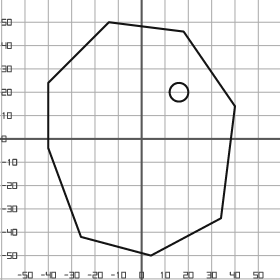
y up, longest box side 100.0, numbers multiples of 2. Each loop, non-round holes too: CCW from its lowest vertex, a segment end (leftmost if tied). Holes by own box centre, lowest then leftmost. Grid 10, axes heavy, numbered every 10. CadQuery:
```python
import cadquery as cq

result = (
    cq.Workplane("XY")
    .moveTo(4.0, -50.0)
    .lineTo(34.0, -34.0)
    .lineTo(40.0, 14.0)
    .lineTo(18.0, 46.0)
    .lineTo(-14.0, 50.0)
    .lineTo(-40.0, 24.0)
    .lineTo(-40.0, -4.0)
    .lineTo(-26.0, -42.0)
    .close()
    .moveTo(16.0, 20.0)
    .circle(4.0)
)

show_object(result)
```